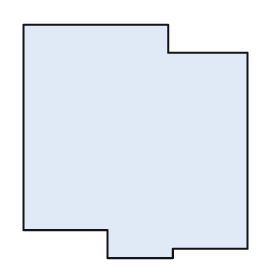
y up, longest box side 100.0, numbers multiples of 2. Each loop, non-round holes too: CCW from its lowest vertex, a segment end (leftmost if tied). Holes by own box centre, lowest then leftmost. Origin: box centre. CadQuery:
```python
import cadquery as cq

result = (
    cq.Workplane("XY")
    .moveTo(-12.0, -50.0)
    .lineTo(16.0, -50.0)
    .lineTo(16.0, -46.0)
    .lineTo(48.0, -46.0)
    .lineTo(48.0, 38.0)
    .lineTo(14.0, 38.0)
    .lineTo(14.0, 50.0)
    .lineTo(-48.0, 50.0)
    .lineTo(-48.0, -38.0)
    .lineTo(-12.0, -38.0)
    .close()
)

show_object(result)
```